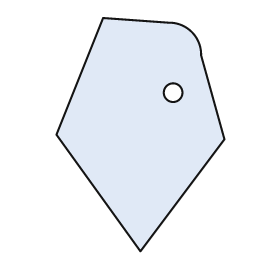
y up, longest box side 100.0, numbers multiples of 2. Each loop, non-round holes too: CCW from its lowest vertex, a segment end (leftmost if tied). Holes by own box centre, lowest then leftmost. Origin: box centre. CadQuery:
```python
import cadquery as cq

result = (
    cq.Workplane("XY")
    .moveTo(0.0, -50.0)
    .lineTo(36.0, -2.0)
    .lineTo(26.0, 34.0)
    .threePointArc((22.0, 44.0), (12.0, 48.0))
    .lineTo(-16.0, 50.0)
    .lineTo(-36.0, 0.0)
    .close()
    .moveTo(14.0, 18.0)
    .circle(4.0)
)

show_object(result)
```